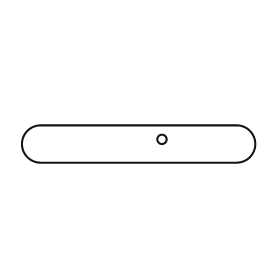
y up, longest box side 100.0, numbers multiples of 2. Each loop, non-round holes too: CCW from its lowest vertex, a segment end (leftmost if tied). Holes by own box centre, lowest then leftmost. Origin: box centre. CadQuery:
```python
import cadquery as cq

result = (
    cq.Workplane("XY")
    .moveTo(-42.0, -8.0)
    .lineTo(42.0, -8.0)
    .threePointArc((50.0, 0.0), (42.0, 8.0))
    .lineTo(-42.0, 8.0)
    .threePointArc((-50.0, 0.0), (-42.0, -8.0))
    .close()
    .moveTo(10.0, 2.0)
    .circle(2.0)
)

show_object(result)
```